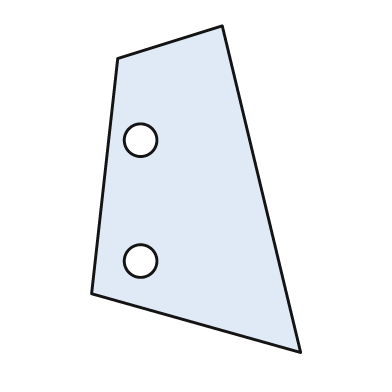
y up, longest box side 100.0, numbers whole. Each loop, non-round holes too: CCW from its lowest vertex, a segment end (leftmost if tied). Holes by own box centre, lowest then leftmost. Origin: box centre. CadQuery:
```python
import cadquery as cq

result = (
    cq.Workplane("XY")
    .moveTo(32.0, -50.0)
    .lineTo(8.0, 50.0)
    .lineTo(-24.0, 40.0)
    .lineTo(-32.0, -32.0)
    .close()
    .moveTo(-17.0, -22.0)
    .circle(5.0)
    .moveTo(-17.0, 15.0)
    .circle(5.0)
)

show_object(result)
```